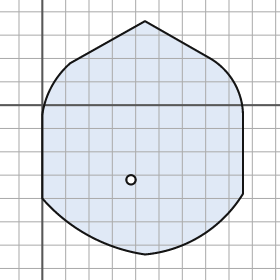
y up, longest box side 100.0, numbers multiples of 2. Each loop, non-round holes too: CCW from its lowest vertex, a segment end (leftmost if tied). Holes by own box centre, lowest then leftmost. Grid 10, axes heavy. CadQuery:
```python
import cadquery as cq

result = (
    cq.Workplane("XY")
    .moveTo(44.0, -64.0)
    .threePointArc((68.0, -56.0), (86.0, -38.0))
    .lineTo(86.0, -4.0)
    .threePointArc((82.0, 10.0), (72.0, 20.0))
    .lineTo(44.0, 36.0)
    .lineTo(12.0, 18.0)
    .threePointArc((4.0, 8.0), (0.0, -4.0))
    .lineTo(0.0, -40.0)
    .threePointArc((20.0, -56.0), (44.0, -64.0))
    .close()
    .moveTo(38.0, -32.0)
    .circle(2.0)
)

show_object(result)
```